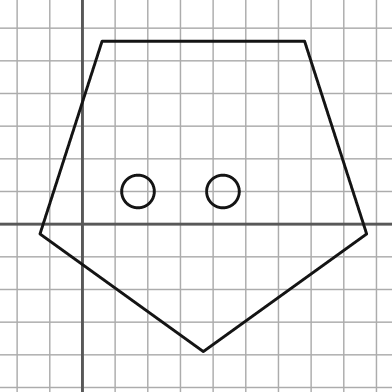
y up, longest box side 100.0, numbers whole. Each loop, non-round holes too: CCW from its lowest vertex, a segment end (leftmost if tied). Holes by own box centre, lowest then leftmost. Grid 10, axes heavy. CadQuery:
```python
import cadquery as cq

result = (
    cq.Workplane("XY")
    .moveTo(37.0, -39.0)
    .lineTo(87.0, -3.0)
    .lineTo(68.0, 56.0)
    .lineTo(6.0, 56.0)
    .lineTo(-13.0, -3.0)
    .close()
    .moveTo(17.0, 10.0)
    .circle(5.0)
    .moveTo(43.0, 10.0)
    .circle(5.0)
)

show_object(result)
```